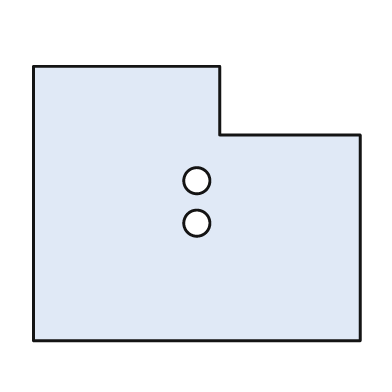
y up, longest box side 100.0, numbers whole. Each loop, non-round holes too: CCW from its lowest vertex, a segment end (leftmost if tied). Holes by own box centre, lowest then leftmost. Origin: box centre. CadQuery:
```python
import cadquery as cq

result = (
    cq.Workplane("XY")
    .moveTo(-50.0, -42.0)
    .lineTo(50.0, -42.0)
    .lineTo(50.0, 21.0)
    .lineTo(7.0, 21.0)
    .lineTo(7.0, 42.0)
    .lineTo(-50.0, 42.0)
    .close()
    .moveTo(0.0, -6.0)
    .circle(4.0)
    .moveTo(0.0, 7.0)
    .circle(4.0)
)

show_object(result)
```